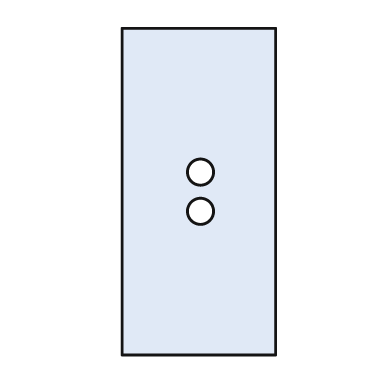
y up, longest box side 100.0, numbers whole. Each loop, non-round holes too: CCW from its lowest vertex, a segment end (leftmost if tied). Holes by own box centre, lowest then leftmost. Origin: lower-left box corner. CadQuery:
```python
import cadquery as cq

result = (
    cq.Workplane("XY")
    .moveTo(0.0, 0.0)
    .lineTo(47.0, 0.0)
    .lineTo(47.0, 100.0)
    .lineTo(0.0, 100.0)
    .close()
    .moveTo(24.0, 44.0)
    .circle(4.0)
    .moveTo(24.0, 56.0)
    .circle(4.0)
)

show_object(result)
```